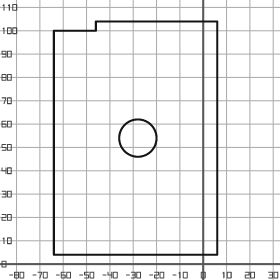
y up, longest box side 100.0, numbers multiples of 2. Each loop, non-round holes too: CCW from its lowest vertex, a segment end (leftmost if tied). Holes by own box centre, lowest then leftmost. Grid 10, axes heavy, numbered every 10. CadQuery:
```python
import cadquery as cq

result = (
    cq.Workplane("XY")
    .moveTo(-64.0, 4.0)
    .lineTo(6.0, 4.0)
    .lineTo(6.0, 104.0)
    .lineTo(-46.0, 104.0)
    .lineTo(-46.0, 100.0)
    .lineTo(-64.0, 100.0)
    .close()
    .moveTo(-28.0, 54.0)
    .circle(8.0)
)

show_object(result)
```